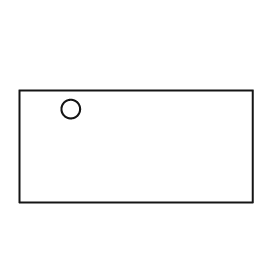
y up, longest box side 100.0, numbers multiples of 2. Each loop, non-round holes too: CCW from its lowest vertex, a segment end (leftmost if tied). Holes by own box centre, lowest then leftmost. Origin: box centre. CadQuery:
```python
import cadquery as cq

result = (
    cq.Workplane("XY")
    .moveTo(-50.0, -24.0)
    .lineTo(50.0, -24.0)
    .lineTo(50.0, 24.0)
    .lineTo(-50.0, 24.0)
    .close()
    .moveTo(-28.0, 16.0)
    .circle(4.0)
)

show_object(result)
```